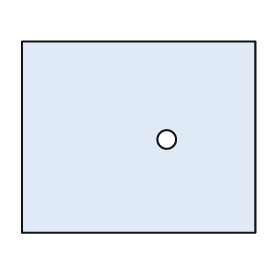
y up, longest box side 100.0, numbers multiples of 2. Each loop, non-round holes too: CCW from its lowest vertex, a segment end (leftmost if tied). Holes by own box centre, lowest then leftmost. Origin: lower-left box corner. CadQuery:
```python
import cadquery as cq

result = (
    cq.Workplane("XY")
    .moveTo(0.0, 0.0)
    .lineTo(100.0, 0.0)
    .lineTo(100.0, 82.0)
    .lineTo(0.0, 82.0)
    .close()
    .moveTo(62.0, 40.0)
    .circle(4.0)
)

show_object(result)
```